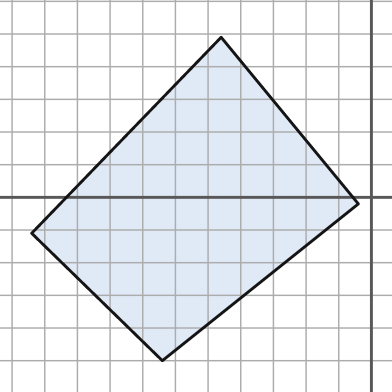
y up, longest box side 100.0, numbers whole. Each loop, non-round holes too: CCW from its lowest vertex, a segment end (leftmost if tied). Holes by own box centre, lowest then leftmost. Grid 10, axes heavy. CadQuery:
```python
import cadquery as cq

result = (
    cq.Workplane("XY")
    .moveTo(-64.0, -50.0)
    .lineTo(-4.0, -2.0)
    .lineTo(-46.0, 49.0)
    .lineTo(-104.0, -11.0)
    .close()
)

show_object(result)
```